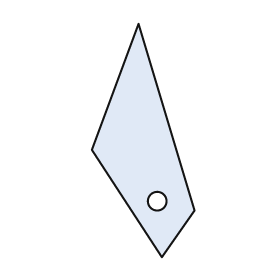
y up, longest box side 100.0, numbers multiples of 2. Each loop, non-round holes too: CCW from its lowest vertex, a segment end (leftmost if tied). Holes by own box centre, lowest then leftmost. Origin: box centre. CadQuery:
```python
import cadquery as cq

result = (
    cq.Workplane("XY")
    .moveTo(8.0, -50.0)
    .lineTo(22.0, -30.0)
    .lineTo(-2.0, 50.0)
    .lineTo(-22.0, -4.0)
    .close()
    .moveTo(6.0, -26.0)
    .circle(4.0)
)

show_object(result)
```